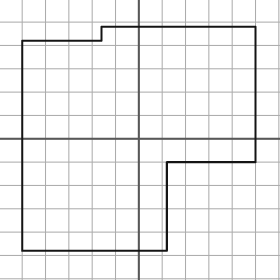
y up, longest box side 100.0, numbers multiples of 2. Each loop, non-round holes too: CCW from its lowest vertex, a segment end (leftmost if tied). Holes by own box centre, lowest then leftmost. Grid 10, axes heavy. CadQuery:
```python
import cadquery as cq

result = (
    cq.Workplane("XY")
    .moveTo(-50.0, -48.0)
    .lineTo(12.0, -48.0)
    .lineTo(12.0, -10.0)
    .lineTo(50.0, -10.0)
    .lineTo(50.0, 48.0)
    .lineTo(-16.0, 48.0)
    .lineTo(-16.0, 42.0)
    .lineTo(-50.0, 42.0)
    .close()
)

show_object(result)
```